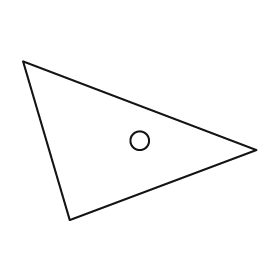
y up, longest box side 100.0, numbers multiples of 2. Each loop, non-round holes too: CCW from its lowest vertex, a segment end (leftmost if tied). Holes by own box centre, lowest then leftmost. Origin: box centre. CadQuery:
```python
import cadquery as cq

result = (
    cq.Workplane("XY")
    .moveTo(-30.0, -34.0)
    .lineTo(50.0, -4.0)
    .lineTo(-50.0, 34.0)
    .close()
    .moveTo(0.0, 0.0)
    .circle(4.0)
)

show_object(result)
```